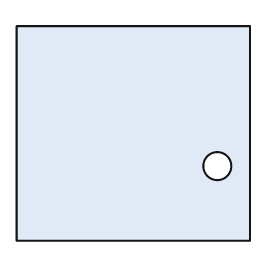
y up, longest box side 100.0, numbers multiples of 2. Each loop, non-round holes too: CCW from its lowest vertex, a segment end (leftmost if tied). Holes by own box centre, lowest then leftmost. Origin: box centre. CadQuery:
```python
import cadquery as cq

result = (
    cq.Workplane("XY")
    .moveTo(-50.0, -46.0)
    .lineTo(50.0, -46.0)
    .lineTo(50.0, 46.0)
    .lineTo(-50.0, 46.0)
    .close()
    .moveTo(36.0, -14.0)
    .circle(6.0)
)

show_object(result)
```